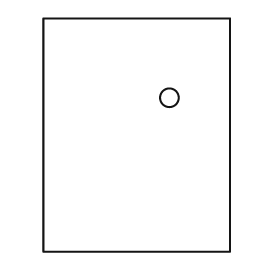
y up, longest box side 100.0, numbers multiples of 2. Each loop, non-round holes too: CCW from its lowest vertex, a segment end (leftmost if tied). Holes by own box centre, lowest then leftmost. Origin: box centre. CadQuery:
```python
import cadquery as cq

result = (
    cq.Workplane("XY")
    .moveTo(-40.0, -50.0)
    .lineTo(40.0, -50.0)
    .lineTo(40.0, 50.0)
    .lineTo(-40.0, 50.0)
    .close()
    .moveTo(14.0, 16.0)
    .circle(4.0)
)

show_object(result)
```